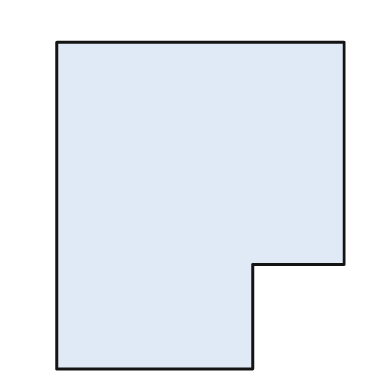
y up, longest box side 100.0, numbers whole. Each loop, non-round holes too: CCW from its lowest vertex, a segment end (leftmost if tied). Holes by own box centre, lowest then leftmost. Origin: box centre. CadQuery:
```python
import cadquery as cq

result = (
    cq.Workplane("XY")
    .moveTo(-44.0, -50.0)
    .lineTo(16.0, -50.0)
    .lineTo(16.0, -18.0)
    .lineTo(44.0, -18.0)
    .lineTo(44.0, 50.0)
    .lineTo(-44.0, 50.0)
    .close()
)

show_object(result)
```